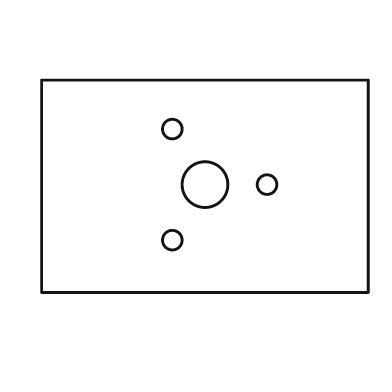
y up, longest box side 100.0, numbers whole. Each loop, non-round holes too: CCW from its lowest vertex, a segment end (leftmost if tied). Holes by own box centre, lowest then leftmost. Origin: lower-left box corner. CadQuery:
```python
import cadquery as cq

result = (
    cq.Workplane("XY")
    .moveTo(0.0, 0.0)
    .lineTo(100.0, 0.0)
    .lineTo(100.0, 65.0)
    .lineTo(0.0, 65.0)
    .close()
    .moveTo(40.0, 16.0)
    .circle(3.0)
    .moveTo(50.0, 33.0)
    .circle(7.0)
    .moveTo(69.0, 33.0)
    .circle(3.0)
    .moveTo(40.0, 50.0)
    .circle(3.0)
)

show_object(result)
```